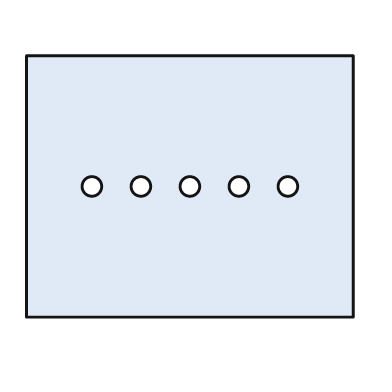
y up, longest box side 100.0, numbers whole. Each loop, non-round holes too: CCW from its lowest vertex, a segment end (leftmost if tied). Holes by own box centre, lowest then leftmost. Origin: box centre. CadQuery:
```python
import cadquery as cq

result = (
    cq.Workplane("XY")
    .moveTo(-50.0, -40.0)
    .lineTo(50.0, -40.0)
    .lineTo(50.0, 40.0)
    .lineTo(-50.0, 40.0)
    .close()
    .moveTo(-30.0, 0.0)
    .circle(3.0)
    .moveTo(-15.0, 0.0)
    .circle(3.0)
    .moveTo(0.0, 0.0)
    .circle(3.0)
    .moveTo(15.0, 0.0)
    .circle(3.0)
    .moveTo(30.0, 0.0)
    .circle(3.0)
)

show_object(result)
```